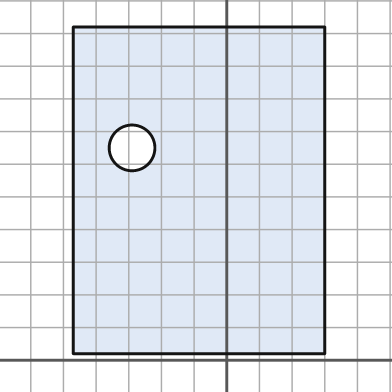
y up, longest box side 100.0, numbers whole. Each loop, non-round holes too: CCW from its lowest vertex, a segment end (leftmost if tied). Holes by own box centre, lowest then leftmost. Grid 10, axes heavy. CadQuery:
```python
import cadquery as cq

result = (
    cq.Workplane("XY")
    .moveTo(-47.0, 2.0)
    .lineTo(30.0, 2.0)
    .lineTo(30.0, 102.0)
    .lineTo(-47.0, 102.0)
    .close()
    .moveTo(-29.0, 65.0)
    .circle(7.0)
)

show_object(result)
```